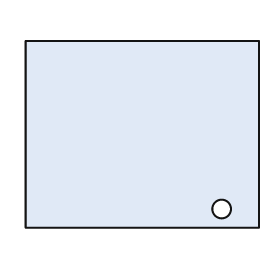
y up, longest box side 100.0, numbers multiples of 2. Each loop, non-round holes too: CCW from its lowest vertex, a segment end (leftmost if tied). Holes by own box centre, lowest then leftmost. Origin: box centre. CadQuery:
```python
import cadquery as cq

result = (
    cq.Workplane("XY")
    .moveTo(-50.0, -40.0)
    .lineTo(50.0, -40.0)
    .lineTo(50.0, 40.0)
    .lineTo(-50.0, 40.0)
    .close()
    .moveTo(34.0, -32.0)
    .circle(4.0)
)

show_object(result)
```